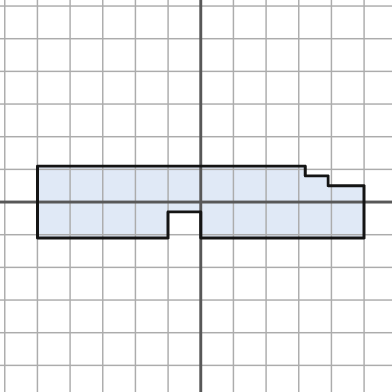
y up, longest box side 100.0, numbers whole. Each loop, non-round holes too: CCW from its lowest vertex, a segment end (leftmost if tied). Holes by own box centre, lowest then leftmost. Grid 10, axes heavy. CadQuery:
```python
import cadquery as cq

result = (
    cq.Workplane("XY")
    .moveTo(-50.0, -11.0)
    .lineTo(-10.0, -11.0)
    .lineTo(-10.0, -3.0)
    .lineTo(0.0, -3.0)
    .lineTo(0.0, -11.0)
    .lineTo(50.0, -11.0)
    .lineTo(50.0, 5.0)
    .lineTo(39.0, 5.0)
    .lineTo(39.0, 8.0)
    .lineTo(32.0, 8.0)
    .lineTo(32.0, 11.0)
    .lineTo(-50.0, 11.0)
    .close()
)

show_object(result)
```